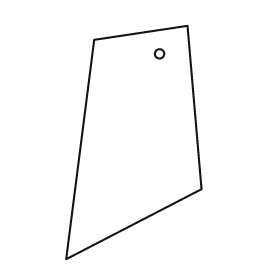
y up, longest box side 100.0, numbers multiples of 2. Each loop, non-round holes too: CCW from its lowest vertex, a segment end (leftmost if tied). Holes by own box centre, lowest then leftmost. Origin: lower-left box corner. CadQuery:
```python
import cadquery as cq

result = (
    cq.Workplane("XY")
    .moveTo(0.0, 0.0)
    .lineTo(58.0, 30.0)
    .lineTo(52.0, 100.0)
    .lineTo(12.0, 94.0)
    .close()
    .moveTo(40.0, 88.0)
    .circle(2.0)
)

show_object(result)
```